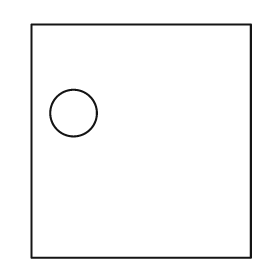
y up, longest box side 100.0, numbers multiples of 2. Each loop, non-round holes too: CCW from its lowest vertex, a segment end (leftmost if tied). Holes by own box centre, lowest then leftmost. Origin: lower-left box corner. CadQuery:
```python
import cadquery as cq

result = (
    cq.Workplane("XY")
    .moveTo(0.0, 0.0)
    .lineTo(94.0, 0.0)
    .lineTo(94.0, 100.0)
    .lineTo(0.0, 100.0)
    .close()
    .moveTo(18.0, 62.0)
    .circle(10.0)
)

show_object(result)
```